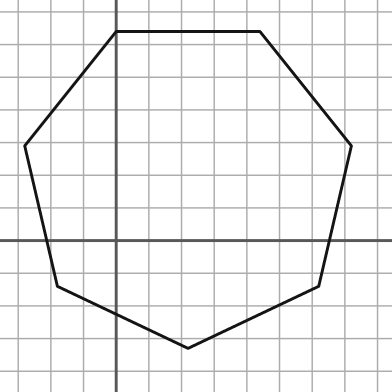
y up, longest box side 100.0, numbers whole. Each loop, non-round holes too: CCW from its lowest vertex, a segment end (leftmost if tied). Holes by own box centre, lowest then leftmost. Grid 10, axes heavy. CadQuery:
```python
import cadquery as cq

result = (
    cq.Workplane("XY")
    .moveTo(22.0, -33.0)
    .lineTo(62.0, -14.0)
    .lineTo(72.0, 29.0)
    .lineTo(44.0, 64.0)
    .lineTo(0.0, 64.0)
    .lineTo(-28.0, 29.0)
    .lineTo(-18.0, -14.0)
    .close()
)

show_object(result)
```